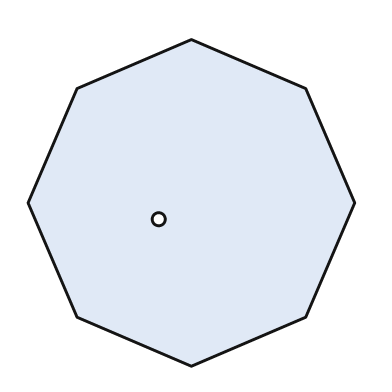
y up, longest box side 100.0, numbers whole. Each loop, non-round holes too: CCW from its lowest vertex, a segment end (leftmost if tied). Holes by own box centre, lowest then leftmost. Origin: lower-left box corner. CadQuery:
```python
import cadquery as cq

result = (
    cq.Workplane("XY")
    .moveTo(50.0, 0.0)
    .lineTo(85.0, 15.0)
    .lineTo(100.0, 50.0)
    .lineTo(85.0, 85.0)
    .lineTo(50.0, 100.0)
    .lineTo(15.0, 85.0)
    .lineTo(0.0, 50.0)
    .lineTo(15.0, 15.0)
    .close()
    .moveTo(40.0, 45.0)
    .circle(2.0)
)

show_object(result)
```